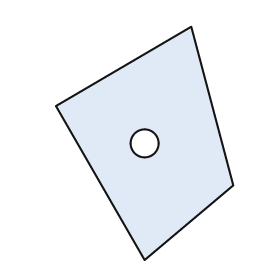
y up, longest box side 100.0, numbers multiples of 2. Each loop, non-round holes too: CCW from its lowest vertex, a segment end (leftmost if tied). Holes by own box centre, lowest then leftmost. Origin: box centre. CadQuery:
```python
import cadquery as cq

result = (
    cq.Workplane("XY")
    .moveTo(0.0, -50.0)
    .lineTo(38.0, -18.0)
    .lineTo(20.0, 50.0)
    .lineTo(-38.0, 16.0)
    .close()
    .moveTo(0.0, 0.0)
    .circle(6.0)
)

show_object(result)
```